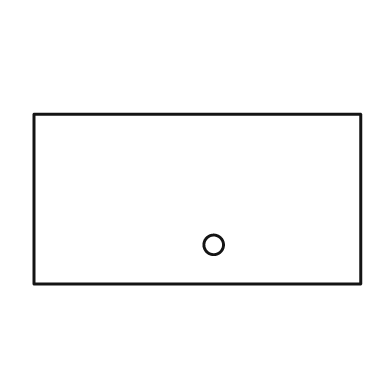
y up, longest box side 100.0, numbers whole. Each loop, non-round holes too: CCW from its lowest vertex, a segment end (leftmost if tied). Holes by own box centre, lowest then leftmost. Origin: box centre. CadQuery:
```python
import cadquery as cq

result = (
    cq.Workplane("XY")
    .moveTo(-50.0, -26.0)
    .lineTo(50.0, -26.0)
    .lineTo(50.0, 26.0)
    .lineTo(-50.0, 26.0)
    .close()
    .moveTo(5.0, -14.0)
    .circle(3.0)
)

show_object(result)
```